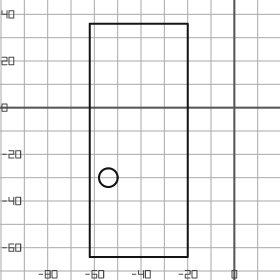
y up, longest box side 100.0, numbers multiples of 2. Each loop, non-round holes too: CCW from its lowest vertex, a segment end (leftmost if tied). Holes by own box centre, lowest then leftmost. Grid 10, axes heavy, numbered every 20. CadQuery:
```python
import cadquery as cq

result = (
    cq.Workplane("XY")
    .moveTo(-62.0, -64.0)
    .lineTo(-20.0, -64.0)
    .lineTo(-20.0, 36.0)
    .lineTo(-62.0, 36.0)
    .close()
    .moveTo(-54.0, -30.0)
    .circle(4.0)
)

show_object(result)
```